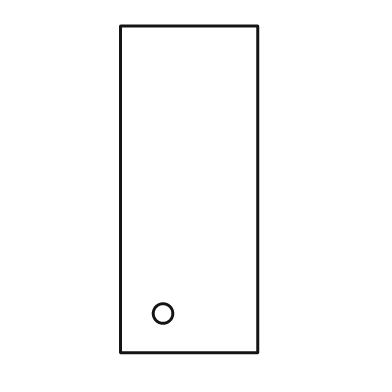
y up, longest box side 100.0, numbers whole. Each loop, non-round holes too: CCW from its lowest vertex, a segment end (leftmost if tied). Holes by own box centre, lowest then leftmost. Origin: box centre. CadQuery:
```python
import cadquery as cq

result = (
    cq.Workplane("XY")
    .moveTo(-21.0, -50.0)
    .lineTo(21.0, -50.0)
    .lineTo(21.0, 50.0)
    .lineTo(-21.0, 50.0)
    .close()
    .moveTo(-8.0, -38.0)
    .circle(3.0)
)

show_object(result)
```